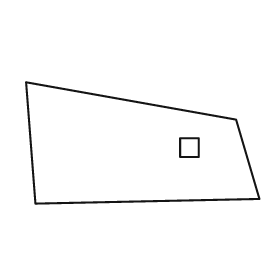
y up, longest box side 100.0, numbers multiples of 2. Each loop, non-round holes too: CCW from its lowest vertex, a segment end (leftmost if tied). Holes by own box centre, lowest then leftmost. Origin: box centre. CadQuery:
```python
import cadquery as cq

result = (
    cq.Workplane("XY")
    .moveTo(-46.0, -26.0)
    .lineTo(50.0, -24.0)
    .lineTo(40.0, 10.0)
    .lineTo(-50.0, 26.0)
    .close()
    .moveTo(16.0, -6.0)
    .lineTo(24.0, -6.0)
    .lineTo(24.0, 2.0)
    .lineTo(16.0, 2.0)
    .close()
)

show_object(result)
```